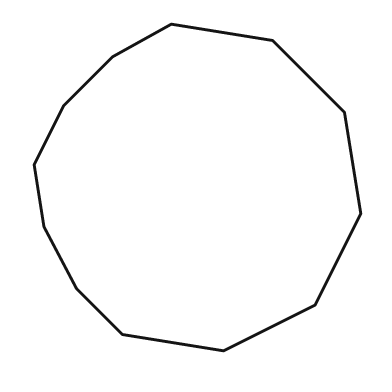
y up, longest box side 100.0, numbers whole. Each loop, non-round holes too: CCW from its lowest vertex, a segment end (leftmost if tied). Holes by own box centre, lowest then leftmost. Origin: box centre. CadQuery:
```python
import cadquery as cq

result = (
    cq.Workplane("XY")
    .moveTo(8.0, -50.0)
    .lineTo(36.0, -36.0)
    .lineTo(50.0, -8.0)
    .lineTo(45.0, 23.0)
    .lineTo(23.0, 45.0)
    .lineTo(-8.0, 50.0)
    .lineTo(-26.0, 40.0)
    .lineTo(-41.0, 25.0)
    .lineTo(-50.0, 7.0)
    .lineTo(-47.0, -12.0)
    .lineTo(-37.0, -31.0)
    .lineTo(-23.0, -45.0)
    .close()
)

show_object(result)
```